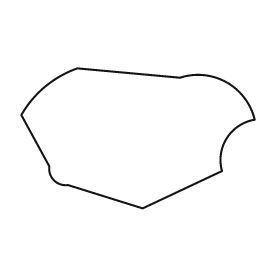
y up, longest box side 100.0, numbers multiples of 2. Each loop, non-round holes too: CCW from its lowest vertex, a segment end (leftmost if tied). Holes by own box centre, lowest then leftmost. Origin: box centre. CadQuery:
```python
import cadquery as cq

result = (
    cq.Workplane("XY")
    .moveTo(2.0, -30.0)
    .lineTo(36.0, -14.0)
    .threePointArc((38.0, 0.0), (50.0, 8.0))
    .threePointArc((38.0, 24.0), (18.0, 26.0))
    .lineTo(-26.0, 30.0)
    .threePointArc((-40.0, 22.0), (-50.0, 10.0))
    .lineTo(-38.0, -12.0)
    .threePointArc((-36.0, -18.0), (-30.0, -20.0))
    .close()
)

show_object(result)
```